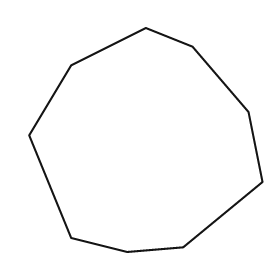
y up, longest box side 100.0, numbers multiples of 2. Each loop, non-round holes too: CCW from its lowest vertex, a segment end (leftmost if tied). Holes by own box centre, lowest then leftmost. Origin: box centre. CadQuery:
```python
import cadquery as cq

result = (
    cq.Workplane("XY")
    .moveTo(-8.0, -48.0)
    .lineTo(16.0, -46.0)
    .lineTo(50.0, -18.0)
    .lineTo(44.0, 12.0)
    .lineTo(20.0, 40.0)
    .lineTo(0.0, 48.0)
    .lineTo(-32.0, 32.0)
    .lineTo(-50.0, 2.0)
    .lineTo(-32.0, -42.0)
    .close()
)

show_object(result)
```